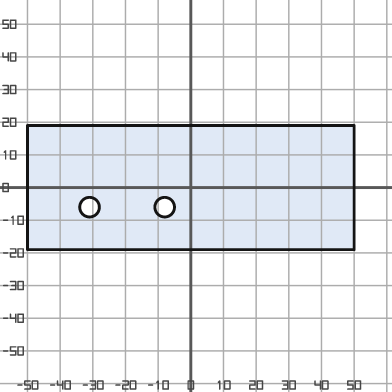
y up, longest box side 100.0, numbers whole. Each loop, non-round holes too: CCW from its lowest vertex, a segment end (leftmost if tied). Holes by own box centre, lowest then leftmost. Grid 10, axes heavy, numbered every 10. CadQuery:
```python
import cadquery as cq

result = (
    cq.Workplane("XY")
    .moveTo(-50.0, -19.0)
    .lineTo(50.0, -19.0)
    .lineTo(50.0, 19.0)
    .lineTo(-50.0, 19.0)
    .close()
    .moveTo(-31.0, -6.0)
    .circle(3.0)
    .moveTo(-8.0, -6.0)
    .circle(3.0)
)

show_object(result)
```